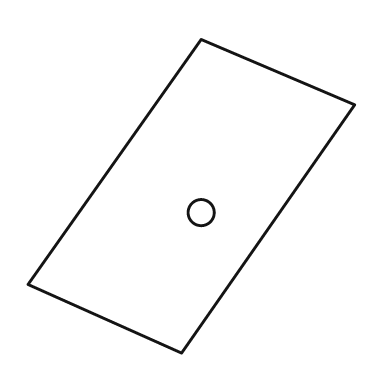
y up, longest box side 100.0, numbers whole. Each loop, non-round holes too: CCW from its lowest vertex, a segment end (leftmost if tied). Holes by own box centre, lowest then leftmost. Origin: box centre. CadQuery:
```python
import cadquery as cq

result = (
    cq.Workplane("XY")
    .moveTo(-3.0, -48.0)
    .lineTo(50.0, 28.0)
    .lineTo(3.0, 48.0)
    .lineTo(-50.0, -27.0)
    .close()
    .moveTo(3.0, -5.0)
    .circle(4.0)
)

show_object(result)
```